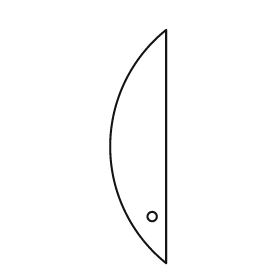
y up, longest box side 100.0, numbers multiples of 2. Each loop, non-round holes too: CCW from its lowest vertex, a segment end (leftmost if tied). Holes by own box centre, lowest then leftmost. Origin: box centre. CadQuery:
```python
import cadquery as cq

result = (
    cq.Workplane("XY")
    .moveTo(12.0, -50.0)
    .lineTo(12.0, 50.0)
    .threePointArc((-12.0, 0.0), (12.0, -50.0))
    .close()
    .moveTo(6.0, -30.0)
    .circle(2.0)
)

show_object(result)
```